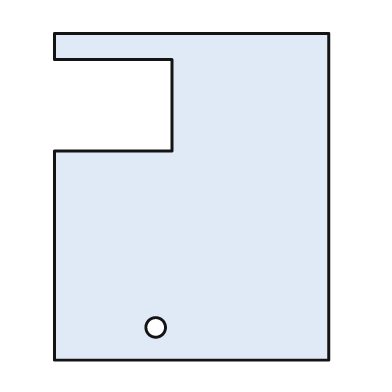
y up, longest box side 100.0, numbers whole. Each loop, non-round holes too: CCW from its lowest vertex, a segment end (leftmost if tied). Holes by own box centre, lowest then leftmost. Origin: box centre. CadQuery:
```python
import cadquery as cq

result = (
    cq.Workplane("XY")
    .moveTo(-42.0, -50.0)
    .lineTo(42.0, -50.0)
    .lineTo(42.0, 50.0)
    .lineTo(-42.0, 50.0)
    .lineTo(-42.0, 42.0)
    .lineTo(-6.0, 42.0)
    .lineTo(-6.0, 14.0)
    .lineTo(-42.0, 14.0)
    .close()
    .moveTo(-11.0, -40.0)
    .circle(3.0)
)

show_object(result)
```